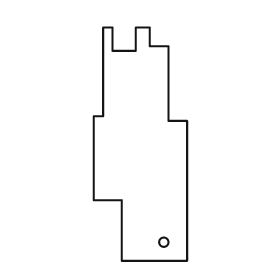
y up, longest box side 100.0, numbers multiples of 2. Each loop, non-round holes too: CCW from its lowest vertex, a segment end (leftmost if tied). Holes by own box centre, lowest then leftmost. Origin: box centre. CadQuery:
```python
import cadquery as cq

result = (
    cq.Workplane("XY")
    .moveTo(-8.0, -50.0)
    .lineTo(20.0, -50.0)
    .lineTo(20.0, 10.0)
    .lineTo(12.0, 10.0)
    .lineTo(12.0, 42.0)
    .lineTo(4.0, 42.0)
    .lineTo(4.0, 50.0)
    .lineTo(-2.0, 50.0)
    .lineTo(-2.0, 40.0)
    .lineTo(-12.0, 40.0)
    .lineTo(-12.0, 50.0)
    .lineTo(-16.0, 50.0)
    .lineTo(-16.0, 12.0)
    .lineTo(-20.0, 12.0)
    .lineTo(-20.0, -24.0)
    .lineTo(-8.0, -24.0)
    .close()
    .moveTo(10.0, -42.0)
    .circle(2.0)
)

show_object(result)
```